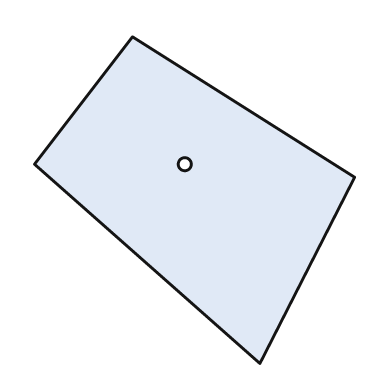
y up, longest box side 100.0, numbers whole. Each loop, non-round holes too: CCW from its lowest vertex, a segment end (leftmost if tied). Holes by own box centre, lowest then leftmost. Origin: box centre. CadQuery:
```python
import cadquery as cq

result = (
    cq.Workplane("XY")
    .moveTo(20.0, -50.0)
    .lineTo(49.0, 7.0)
    .lineTo(-19.0, 50.0)
    .lineTo(-49.0, 11.0)
    .close()
    .moveTo(-3.0, 11.0)
    .circle(2.0)
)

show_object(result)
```